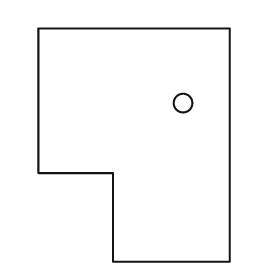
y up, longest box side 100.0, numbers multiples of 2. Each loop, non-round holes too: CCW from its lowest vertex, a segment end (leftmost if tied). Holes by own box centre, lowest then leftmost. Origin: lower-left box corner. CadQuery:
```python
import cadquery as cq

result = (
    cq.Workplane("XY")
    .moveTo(32.0, 0.0)
    .lineTo(82.0, 0.0)
    .lineTo(82.0, 100.0)
    .lineTo(0.0, 100.0)
    .lineTo(0.0, 38.0)
    .lineTo(32.0, 38.0)
    .close()
    .moveTo(62.0, 68.0)
    .circle(4.0)
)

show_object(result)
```